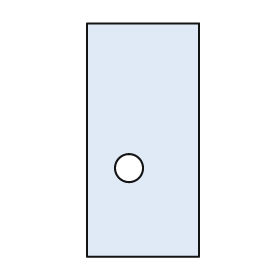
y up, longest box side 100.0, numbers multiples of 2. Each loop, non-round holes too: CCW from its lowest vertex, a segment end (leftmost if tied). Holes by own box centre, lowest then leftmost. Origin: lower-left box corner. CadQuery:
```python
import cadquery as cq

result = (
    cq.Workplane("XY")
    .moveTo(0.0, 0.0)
    .lineTo(48.0, 0.0)
    .lineTo(48.0, 100.0)
    .lineTo(0.0, 100.0)
    .close()
    .moveTo(18.0, 38.0)
    .circle(6.0)
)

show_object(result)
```